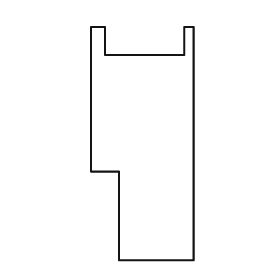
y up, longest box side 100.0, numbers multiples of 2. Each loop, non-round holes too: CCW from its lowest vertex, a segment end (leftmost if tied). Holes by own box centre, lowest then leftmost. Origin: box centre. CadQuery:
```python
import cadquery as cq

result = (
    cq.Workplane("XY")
    .moveTo(-10.0, -50.0)
    .lineTo(22.0, -50.0)
    .lineTo(22.0, 50.0)
    .lineTo(18.0, 50.0)
    .lineTo(18.0, 38.0)
    .lineTo(-16.0, 38.0)
    .lineTo(-16.0, 50.0)
    .lineTo(-22.0, 50.0)
    .lineTo(-22.0, -12.0)
    .lineTo(-10.0, -12.0)
    .close()
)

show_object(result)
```